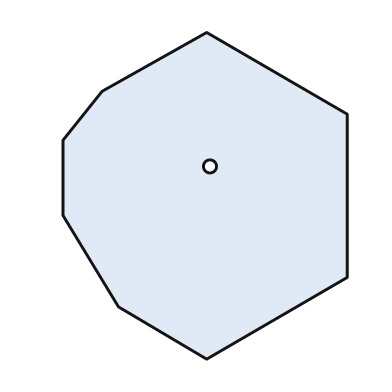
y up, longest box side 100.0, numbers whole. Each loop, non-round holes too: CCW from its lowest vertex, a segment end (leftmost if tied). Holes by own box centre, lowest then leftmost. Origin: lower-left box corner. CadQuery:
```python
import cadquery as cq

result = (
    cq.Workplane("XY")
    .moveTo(44.0, 0.0)
    .lineTo(87.0, 25.0)
    .lineTo(87.0, 75.0)
    .lineTo(44.0, 100.0)
    .lineTo(12.0, 82.0)
    .lineTo(0.0, 67.0)
    .lineTo(0.0, 44.0)
    .lineTo(17.0, 16.0)
    .close()
    .moveTo(45.0, 59.0)
    .circle(2.0)
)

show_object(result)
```